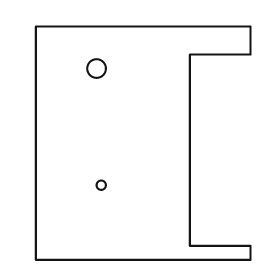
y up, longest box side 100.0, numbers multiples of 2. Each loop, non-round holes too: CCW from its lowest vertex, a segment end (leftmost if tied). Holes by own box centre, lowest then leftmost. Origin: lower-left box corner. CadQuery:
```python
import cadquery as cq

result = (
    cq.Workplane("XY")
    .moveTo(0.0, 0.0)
    .lineTo(92.0, 0.0)
    .lineTo(92.0, 6.0)
    .lineTo(66.0, 6.0)
    .lineTo(66.0, 88.0)
    .lineTo(92.0, 88.0)
    .lineTo(92.0, 100.0)
    .lineTo(0.0, 100.0)
    .close()
    .moveTo(28.0, 32.0)
    .circle(2.0)
    .moveTo(26.0, 82.0)
    .circle(4.0)
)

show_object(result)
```